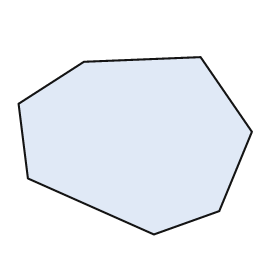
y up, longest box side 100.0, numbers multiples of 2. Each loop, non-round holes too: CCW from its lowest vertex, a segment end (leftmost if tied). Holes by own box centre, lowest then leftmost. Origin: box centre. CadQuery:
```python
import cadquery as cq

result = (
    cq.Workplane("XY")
    .moveTo(8.0, -38.0)
    .lineTo(36.0, -28.0)
    .lineTo(50.0, 6.0)
    .lineTo(28.0, 38.0)
    .lineTo(-22.0, 36.0)
    .lineTo(-50.0, 18.0)
    .lineTo(-46.0, -14.0)
    .close()
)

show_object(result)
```